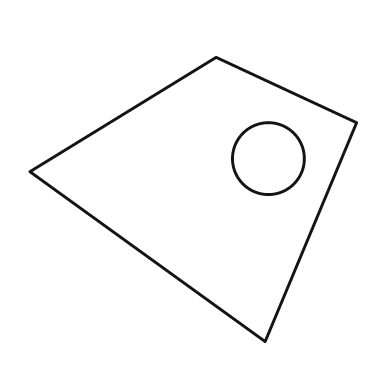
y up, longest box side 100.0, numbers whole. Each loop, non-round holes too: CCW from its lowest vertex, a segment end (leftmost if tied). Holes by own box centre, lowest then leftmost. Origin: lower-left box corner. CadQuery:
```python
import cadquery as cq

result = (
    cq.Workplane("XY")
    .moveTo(72.0, 0.0)
    .lineTo(100.0, 67.0)
    .lineTo(57.0, 87.0)
    .lineTo(0.0, 52.0)
    .close()
    .moveTo(73.0, 56.0)
    .circle(11.0)
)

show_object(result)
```